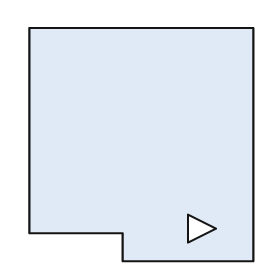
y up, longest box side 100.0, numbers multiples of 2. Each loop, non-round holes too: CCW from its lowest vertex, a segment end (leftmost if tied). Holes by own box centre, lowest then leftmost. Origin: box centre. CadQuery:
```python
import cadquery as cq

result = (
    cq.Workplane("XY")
    .moveTo(-8.0, -50.0)
    .lineTo(48.0, -50.0)
    .lineTo(48.0, 50.0)
    .lineTo(-48.0, 50.0)
    .lineTo(-48.0, -38.0)
    .lineTo(-8.0, -38.0)
    .close()
    .moveTo(20.0, -42.0)
    .lineTo(32.0, -36.0)
    .lineTo(20.0, -30.0)
    .close()
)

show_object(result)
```